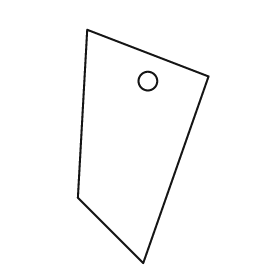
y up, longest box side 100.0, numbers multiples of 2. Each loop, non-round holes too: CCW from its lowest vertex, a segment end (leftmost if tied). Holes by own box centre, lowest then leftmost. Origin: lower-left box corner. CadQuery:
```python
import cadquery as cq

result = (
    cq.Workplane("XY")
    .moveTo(28.0, 0.0)
    .lineTo(56.0, 80.0)
    .lineTo(4.0, 100.0)
    .lineTo(0.0, 28.0)
    .close()
    .moveTo(30.0, 78.0)
    .circle(4.0)
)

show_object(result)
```